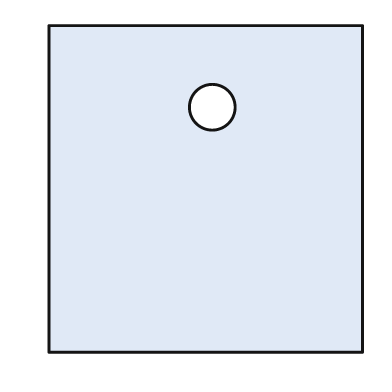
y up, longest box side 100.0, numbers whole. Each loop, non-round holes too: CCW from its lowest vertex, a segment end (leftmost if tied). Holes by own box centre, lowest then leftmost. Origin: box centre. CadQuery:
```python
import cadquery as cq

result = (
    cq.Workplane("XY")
    .moveTo(-48.0, -50.0)
    .lineTo(48.0, -50.0)
    .lineTo(48.0, 50.0)
    .lineTo(-48.0, 50.0)
    .close()
    .moveTo(2.0, 25.0)
    .circle(7.0)
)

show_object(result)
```